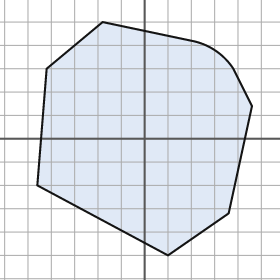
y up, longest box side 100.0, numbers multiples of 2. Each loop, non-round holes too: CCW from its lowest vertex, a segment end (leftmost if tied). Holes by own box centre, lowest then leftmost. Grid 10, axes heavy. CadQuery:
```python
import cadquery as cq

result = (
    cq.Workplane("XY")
    .moveTo(10.0, -50.0)
    .lineTo(36.0, -32.0)
    .lineTo(46.0, 14.0)
    .lineTo(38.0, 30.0)
    .threePointArc((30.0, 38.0), (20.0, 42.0))
    .lineTo(-18.0, 50.0)
    .lineTo(-42.0, 30.0)
    .lineTo(-46.0, -20.0)
    .close()
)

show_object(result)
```